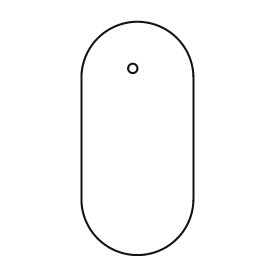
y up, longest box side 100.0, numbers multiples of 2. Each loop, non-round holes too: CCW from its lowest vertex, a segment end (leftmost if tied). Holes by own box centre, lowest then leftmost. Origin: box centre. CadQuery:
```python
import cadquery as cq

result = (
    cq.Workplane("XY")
    .moveTo(-24.0, -26.0)
    .threePointArc((0.0, -50.0), (24.0, -26.0))
    .lineTo(24.0, 26.0)
    .threePointArc((0.0, 50.0), (-24.0, 26.0))
    .close()
    .moveTo(-2.0, 30.0)
    .circle(2.0)
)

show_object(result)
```